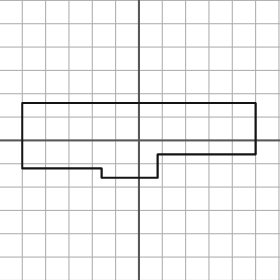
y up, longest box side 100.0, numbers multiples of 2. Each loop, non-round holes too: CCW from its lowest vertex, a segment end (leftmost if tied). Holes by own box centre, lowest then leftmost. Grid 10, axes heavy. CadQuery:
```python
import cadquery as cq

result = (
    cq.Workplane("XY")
    .moveTo(-16.0, -16.0)
    .lineTo(8.0, -16.0)
    .lineTo(8.0, -6.0)
    .lineTo(50.0, -6.0)
    .lineTo(50.0, 16.0)
    .lineTo(-50.0, 16.0)
    .lineTo(-50.0, -12.0)
    .lineTo(-16.0, -12.0)
    .close()
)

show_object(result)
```